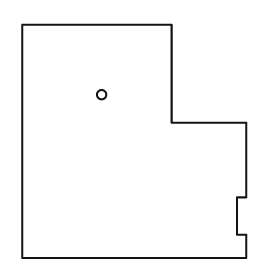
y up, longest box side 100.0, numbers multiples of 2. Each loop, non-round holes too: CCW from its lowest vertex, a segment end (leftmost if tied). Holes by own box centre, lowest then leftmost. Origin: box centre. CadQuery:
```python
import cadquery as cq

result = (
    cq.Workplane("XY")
    .moveTo(-48.0, -50.0)
    .lineTo(48.0, -50.0)
    .lineTo(48.0, -40.0)
    .lineTo(44.0, -40.0)
    .lineTo(44.0, -24.0)
    .lineTo(48.0, -24.0)
    .lineTo(48.0, 8.0)
    .lineTo(16.0, 8.0)
    .lineTo(16.0, 50.0)
    .lineTo(-48.0, 50.0)
    .close()
    .moveTo(-14.0, 20.0)
    .circle(2.0)
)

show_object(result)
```